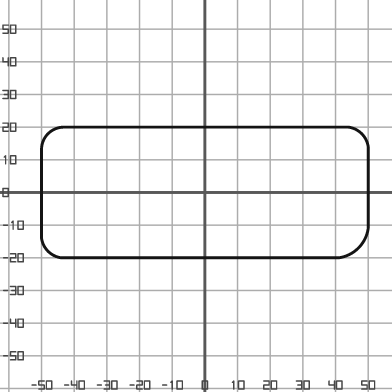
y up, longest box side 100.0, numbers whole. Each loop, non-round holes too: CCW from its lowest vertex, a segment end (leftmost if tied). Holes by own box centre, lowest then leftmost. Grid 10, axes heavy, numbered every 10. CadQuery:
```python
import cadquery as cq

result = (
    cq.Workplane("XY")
    .moveTo(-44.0, -20.0)
    .lineTo(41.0, -20.0)
    .threePointArc((47.0, -17.0), (50.0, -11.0))
    .lineTo(50.0, 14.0)
    .threePointArc((48.0, 18.0), (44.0, 20.0))
    .lineTo(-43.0, 20.0)
    .threePointArc((-48.0, 18.0), (-50.0, 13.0))
    .lineTo(-50.0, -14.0)
    .threePointArc((-48.0, -18.0), (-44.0, -20.0))
    .close()
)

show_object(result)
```